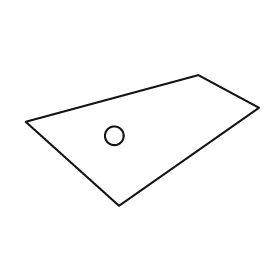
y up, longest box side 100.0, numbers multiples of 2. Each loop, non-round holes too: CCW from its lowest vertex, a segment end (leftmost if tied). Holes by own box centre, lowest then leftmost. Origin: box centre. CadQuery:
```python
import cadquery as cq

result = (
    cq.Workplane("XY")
    .moveTo(-10.0, -28.0)
    .lineTo(50.0, 14.0)
    .lineTo(24.0, 28.0)
    .lineTo(-50.0, 8.0)
    .close()
    .moveTo(-12.0, 2.0)
    .circle(4.0)
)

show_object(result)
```